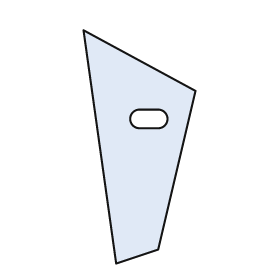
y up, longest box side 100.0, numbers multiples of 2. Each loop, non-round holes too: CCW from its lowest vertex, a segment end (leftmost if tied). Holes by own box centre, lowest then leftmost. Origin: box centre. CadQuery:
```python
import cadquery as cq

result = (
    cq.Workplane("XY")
    .moveTo(-10.0, -50.0)
    .lineTo(8.0, -44.0)
    .lineTo(24.0, 24.0)
    .lineTo(-24.0, 50.0)
    .close()
    .moveTo(0.0, 8.0)
    .lineTo(8.0, 8.0)
    .threePointArc((12.0, 12.0), (8.0, 16.0))
    .lineTo(0.0, 16.0)
    .threePointArc((-4.0, 12.0), (0.0, 8.0))
    .close()
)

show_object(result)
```